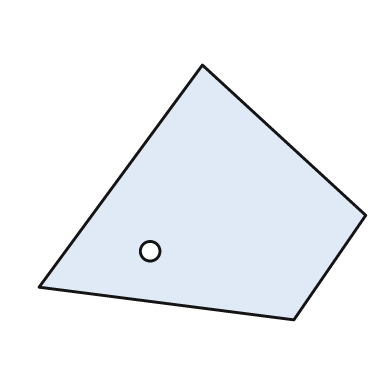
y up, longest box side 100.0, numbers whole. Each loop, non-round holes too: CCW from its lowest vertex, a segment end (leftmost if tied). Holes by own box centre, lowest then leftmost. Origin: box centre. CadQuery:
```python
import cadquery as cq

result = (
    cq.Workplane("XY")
    .moveTo(28.0, -39.0)
    .lineTo(50.0, -7.0)
    .lineTo(0.0, 39.0)
    .lineTo(-50.0, -29.0)
    .close()
    .moveTo(-16.0, -18.0)
    .circle(3.0)
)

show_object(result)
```